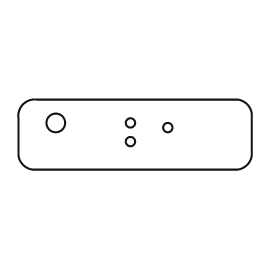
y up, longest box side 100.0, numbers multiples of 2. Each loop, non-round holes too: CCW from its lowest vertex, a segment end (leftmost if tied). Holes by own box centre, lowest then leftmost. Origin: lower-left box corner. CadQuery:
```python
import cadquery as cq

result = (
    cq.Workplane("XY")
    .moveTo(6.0, 0.0)
    .lineTo(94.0, 0.0)
    .threePointArc((98.0, 2.0), (100.0, 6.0))
    .lineTo(100.0, 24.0)
    .threePointArc((98.0, 28.0), (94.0, 30.0))
    .lineTo(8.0, 30.0)
    .threePointArc((2.0, 28.0), (0.0, 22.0))
    .lineTo(0.0, 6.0)
    .threePointArc((2.0, 2.0), (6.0, 0.0))
    .close()
    .moveTo(48.0, 12.0)
    .circle(2.0)
    .moveTo(64.0, 18.0)
    .circle(2.0)
    .moveTo(16.0, 20.0)
    .circle(4.0)
    .moveTo(48.0, 20.0)
    .circle(2.0)
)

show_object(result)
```